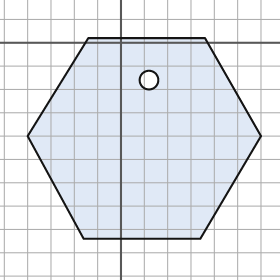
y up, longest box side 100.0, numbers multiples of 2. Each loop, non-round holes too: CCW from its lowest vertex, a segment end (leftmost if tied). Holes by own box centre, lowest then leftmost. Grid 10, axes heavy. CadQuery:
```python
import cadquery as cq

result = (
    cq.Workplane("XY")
    .moveTo(-16.0, -84.0)
    .lineTo(34.0, -84.0)
    .lineTo(60.0, -40.0)
    .lineTo(36.0, 2.0)
    .lineTo(-14.0, 2.0)
    .lineTo(-40.0, -40.0)
    .close()
    .moveTo(12.0, -16.0)
    .circle(4.0)
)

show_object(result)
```